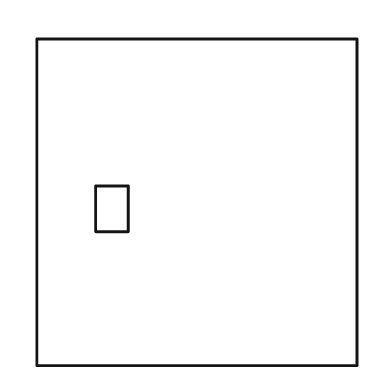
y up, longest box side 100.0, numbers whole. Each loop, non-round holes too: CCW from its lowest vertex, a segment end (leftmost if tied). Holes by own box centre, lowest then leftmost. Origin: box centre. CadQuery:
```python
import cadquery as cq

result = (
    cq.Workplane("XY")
    .moveTo(-49.0, -50.0)
    .lineTo(49.0, -50.0)
    .lineTo(49.0, 50.0)
    .lineTo(-49.0, 50.0)
    .close()
    .moveTo(-31.0, -9.0)
    .lineTo(-21.0, -9.0)
    .lineTo(-21.0, 5.0)
    .lineTo(-31.0, 5.0)
    .close()
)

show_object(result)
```